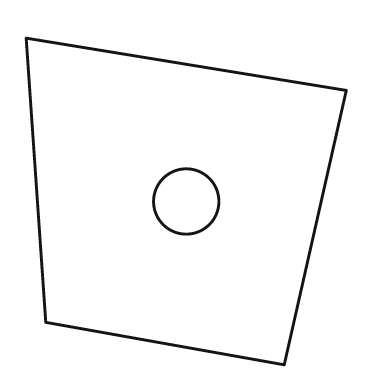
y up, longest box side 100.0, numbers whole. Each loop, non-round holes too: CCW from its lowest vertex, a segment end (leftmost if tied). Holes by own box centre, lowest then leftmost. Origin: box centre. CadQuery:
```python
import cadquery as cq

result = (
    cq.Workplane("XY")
    .moveTo(30.0, -50.0)
    .lineTo(49.0, 34.0)
    .lineTo(-49.0, 50.0)
    .lineTo(-43.0, -37.0)
    .close()
    .moveTo(0.0, 0.0)
    .circle(10.0)
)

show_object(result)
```